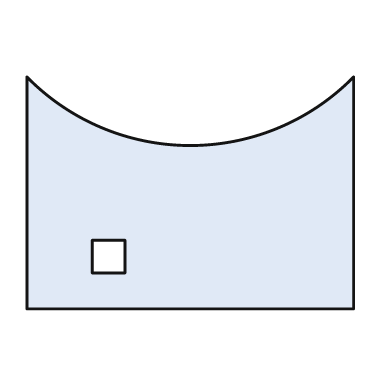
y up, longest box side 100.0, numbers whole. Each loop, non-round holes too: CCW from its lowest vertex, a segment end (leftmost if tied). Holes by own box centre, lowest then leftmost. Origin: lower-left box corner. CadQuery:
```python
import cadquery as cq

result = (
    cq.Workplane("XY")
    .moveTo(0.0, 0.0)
    .lineTo(100.0, 0.0)
    .lineTo(100.0, 71.0)
    .threePointArc((50.0, 50.0), (0.0, 71.0))
    .close()
    .moveTo(20.0, 11.0)
    .lineTo(30.0, 11.0)
    .lineTo(30.0, 21.0)
    .lineTo(20.0, 21.0)
    .close()
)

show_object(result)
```